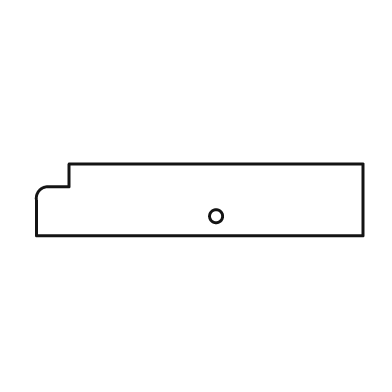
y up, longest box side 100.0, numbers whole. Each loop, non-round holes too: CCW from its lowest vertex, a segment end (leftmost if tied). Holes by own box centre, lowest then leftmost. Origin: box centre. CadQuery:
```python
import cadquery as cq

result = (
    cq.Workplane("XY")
    .moveTo(-50.0, -11.0)
    .lineTo(50.0, -11.0)
    .lineTo(50.0, 11.0)
    .lineTo(-40.0, 11.0)
    .lineTo(-40.0, 4.0)
    .lineTo(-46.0, 4.0)
    .threePointArc((-49.0, 3.0), (-50.0, 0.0))
    .close()
    .moveTo(5.0, -5.0)
    .circle(2.0)
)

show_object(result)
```